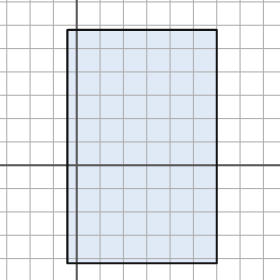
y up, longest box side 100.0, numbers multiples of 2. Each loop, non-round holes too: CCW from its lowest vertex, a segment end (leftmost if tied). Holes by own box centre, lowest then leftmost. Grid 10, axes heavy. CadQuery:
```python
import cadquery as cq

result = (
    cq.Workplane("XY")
    .moveTo(-4.0, -42.0)
    .lineTo(60.0, -42.0)
    .lineTo(60.0, 58.0)
    .lineTo(-4.0, 58.0)
    .close()
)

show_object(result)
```